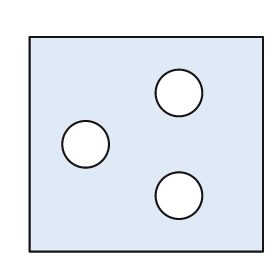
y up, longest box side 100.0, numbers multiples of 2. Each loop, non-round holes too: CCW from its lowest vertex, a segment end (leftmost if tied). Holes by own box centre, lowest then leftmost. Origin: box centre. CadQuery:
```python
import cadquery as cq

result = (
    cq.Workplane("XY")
    .moveTo(-50.0, -46.0)
    .lineTo(50.0, -46.0)
    .lineTo(50.0, 46.0)
    .lineTo(-50.0, 46.0)
    .close()
    .moveTo(14.0, -22.0)
    .circle(10.0)
    .moveTo(-26.0, 0.0)
    .circle(10.0)
    .moveTo(14.0, 22.0)
    .circle(10.0)
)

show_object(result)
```